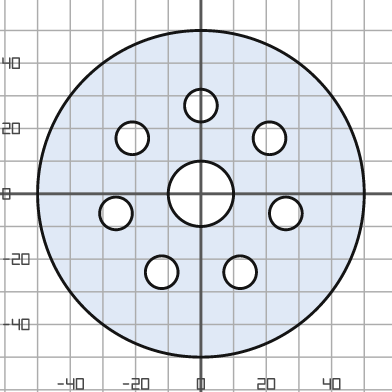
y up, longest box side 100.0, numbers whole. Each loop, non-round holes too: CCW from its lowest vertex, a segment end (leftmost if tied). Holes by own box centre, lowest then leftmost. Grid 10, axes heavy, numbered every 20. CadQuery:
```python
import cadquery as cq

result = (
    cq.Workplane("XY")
    .moveTo(0.0, 0.0)
    .circle(50.0)
    .moveTo(-12.0, -24.0)
    .circle(5.0)
    .moveTo(12.0, -24.0)
    .circle(5.0)
    .moveTo(-26.0, -6.0)
    .circle(5.0)
    .moveTo(26.0, -6.0)
    .circle(5.0)
    .moveTo(0.0, 0.0)
    .circle(10.0)
    .moveTo(-21.0, 17.0)
    .circle(5.0)
    .moveTo(21.0, 17.0)
    .circle(5.0)
    .moveTo(0.0, 27.0)
    .circle(5.0)
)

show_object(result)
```